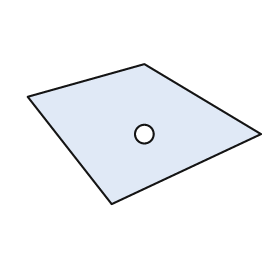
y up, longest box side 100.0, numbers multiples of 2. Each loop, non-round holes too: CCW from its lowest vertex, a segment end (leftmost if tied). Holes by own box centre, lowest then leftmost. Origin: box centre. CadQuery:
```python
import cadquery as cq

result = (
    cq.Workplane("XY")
    .moveTo(-14.0, -30.0)
    .lineTo(50.0, 0.0)
    .lineTo(0.0, 30.0)
    .lineTo(-50.0, 16.0)
    .close()
    .moveTo(0.0, 0.0)
    .circle(4.0)
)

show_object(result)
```